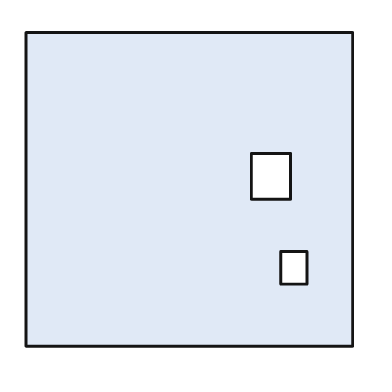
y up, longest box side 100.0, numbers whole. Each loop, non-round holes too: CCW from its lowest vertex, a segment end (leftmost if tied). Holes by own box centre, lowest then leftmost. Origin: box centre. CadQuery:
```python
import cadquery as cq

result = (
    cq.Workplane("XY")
    .moveTo(-50.0, -48.0)
    .lineTo(50.0, -48.0)
    .lineTo(50.0, 48.0)
    .lineTo(-50.0, 48.0)
    .close()
    .moveTo(28.0, -29.0)
    .lineTo(36.0, -29.0)
    .lineTo(36.0, -19.0)
    .lineTo(28.0, -19.0)
    .close()
    .moveTo(19.0, -3.0)
    .lineTo(31.0, -3.0)
    .lineTo(31.0, 11.0)
    .lineTo(19.0, 11.0)
    .close()
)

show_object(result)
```